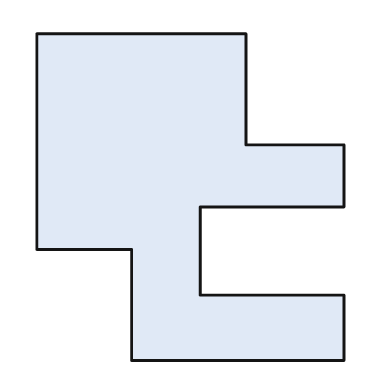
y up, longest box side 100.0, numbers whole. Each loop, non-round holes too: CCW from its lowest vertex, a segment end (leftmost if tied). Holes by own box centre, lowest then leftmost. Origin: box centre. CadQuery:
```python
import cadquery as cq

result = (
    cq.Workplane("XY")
    .moveTo(-18.0, -50.0)
    .lineTo(47.0, -50.0)
    .lineTo(47.0, -30.0)
    .lineTo(3.0, -30.0)
    .lineTo(3.0, -3.0)
    .lineTo(47.0, -3.0)
    .lineTo(47.0, 16.0)
    .lineTo(17.0, 16.0)
    .lineTo(17.0, 50.0)
    .lineTo(-47.0, 50.0)
    .lineTo(-47.0, -16.0)
    .lineTo(-18.0, -16.0)
    .close()
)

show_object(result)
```